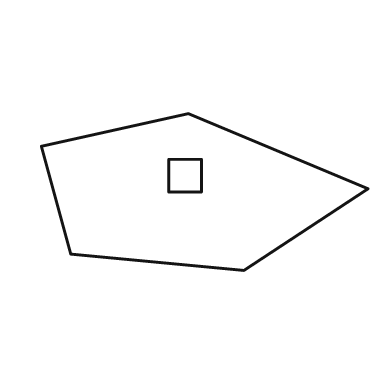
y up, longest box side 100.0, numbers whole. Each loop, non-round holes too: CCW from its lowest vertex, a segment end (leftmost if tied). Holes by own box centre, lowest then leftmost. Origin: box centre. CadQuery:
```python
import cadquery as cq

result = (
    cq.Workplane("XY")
    .moveTo(12.0, -24.0)
    .lineTo(50.0, 1.0)
    .lineTo(-5.0, 24.0)
    .lineTo(-50.0, 14.0)
    .lineTo(-41.0, -19.0)
    .close()
    .moveTo(-11.0, 0.0)
    .lineTo(-1.0, 0.0)
    .lineTo(-1.0, 10.0)
    .lineTo(-11.0, 10.0)
    .close()
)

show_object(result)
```